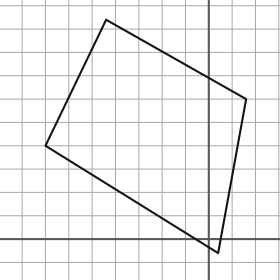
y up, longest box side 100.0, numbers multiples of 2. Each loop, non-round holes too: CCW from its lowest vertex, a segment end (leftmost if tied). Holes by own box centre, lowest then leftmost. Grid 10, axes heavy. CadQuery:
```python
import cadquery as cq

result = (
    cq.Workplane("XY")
    .moveTo(4.0, -6.0)
    .lineTo(16.0, 60.0)
    .lineTo(-44.0, 94.0)
    .lineTo(-70.0, 40.0)
    .close()
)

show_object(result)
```